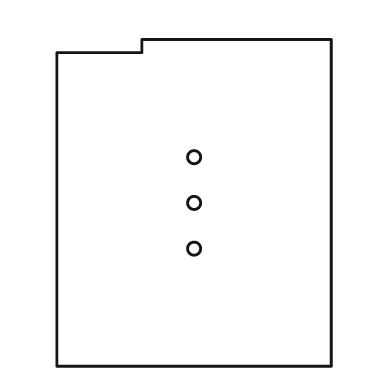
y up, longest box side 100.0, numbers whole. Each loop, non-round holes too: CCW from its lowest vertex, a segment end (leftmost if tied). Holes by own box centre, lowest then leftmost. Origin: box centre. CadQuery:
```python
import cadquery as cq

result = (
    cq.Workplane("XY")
    .moveTo(-42.0, -50.0)
    .lineTo(42.0, -50.0)
    .lineTo(42.0, 50.0)
    .lineTo(-16.0, 50.0)
    .lineTo(-16.0, 46.0)
    .lineTo(-42.0, 46.0)
    .close()
    .moveTo(0.0, -14.0)
    .circle(2.0)
    .moveTo(0.0, 0.0)
    .circle(2.0)
    .moveTo(0.0, 14.0)
    .circle(2.0)
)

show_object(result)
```